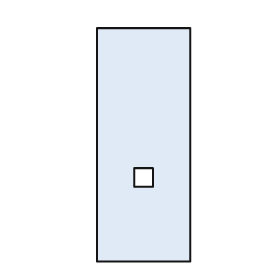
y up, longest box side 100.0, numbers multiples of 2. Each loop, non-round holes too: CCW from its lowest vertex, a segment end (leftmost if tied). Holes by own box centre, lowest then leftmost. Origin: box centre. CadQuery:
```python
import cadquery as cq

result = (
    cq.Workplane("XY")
    .moveTo(-20.0, -50.0)
    .lineTo(20.0, -50.0)
    .lineTo(20.0, 50.0)
    .lineTo(-20.0, 50.0)
    .close()
    .moveTo(-4.0, -18.0)
    .lineTo(4.0, -18.0)
    .lineTo(4.0, -10.0)
    .lineTo(-4.0, -10.0)
    .close()
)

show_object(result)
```